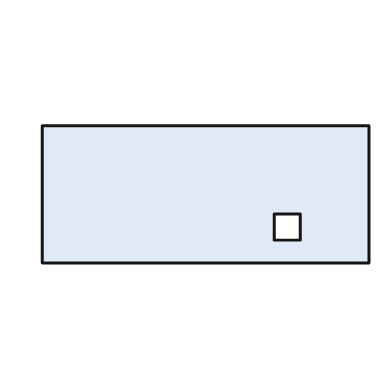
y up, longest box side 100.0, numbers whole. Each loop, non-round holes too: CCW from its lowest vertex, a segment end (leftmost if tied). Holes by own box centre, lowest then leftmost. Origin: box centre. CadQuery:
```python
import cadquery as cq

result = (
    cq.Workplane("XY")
    .moveTo(-50.0, -21.0)
    .lineTo(50.0, -21.0)
    .lineTo(50.0, 21.0)
    .lineTo(-50.0, 21.0)
    .close()
    .moveTo(21.0, -14.0)
    .lineTo(29.0, -14.0)
    .lineTo(29.0, -6.0)
    .lineTo(21.0, -6.0)
    .close()
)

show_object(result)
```